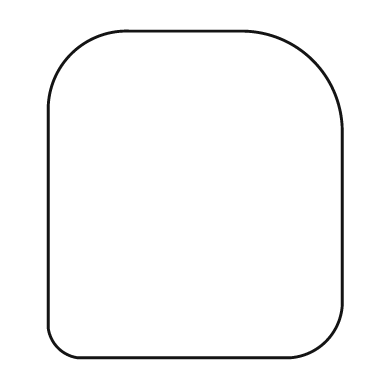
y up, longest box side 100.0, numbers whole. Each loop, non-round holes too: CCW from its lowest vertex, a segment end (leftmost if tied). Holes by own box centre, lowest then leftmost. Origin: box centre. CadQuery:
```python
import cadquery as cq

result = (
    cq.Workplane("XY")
    .moveTo(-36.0, -50.0)
    .lineTo(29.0, -50.0)
    .threePointArc((40.0, -45.0), (45.0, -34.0))
    .lineTo(45.0, 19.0)
    .threePointArc((36.0, 41.0), (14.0, 50.0))
    .lineTo(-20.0, 50.0)
    .threePointArc((-38.0, 43.0), (-45.0, 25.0))
    .lineTo(-45.0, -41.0)
    .threePointArc((-42.0, -47.0), (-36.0, -50.0))
    .close()
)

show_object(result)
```